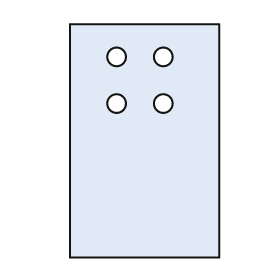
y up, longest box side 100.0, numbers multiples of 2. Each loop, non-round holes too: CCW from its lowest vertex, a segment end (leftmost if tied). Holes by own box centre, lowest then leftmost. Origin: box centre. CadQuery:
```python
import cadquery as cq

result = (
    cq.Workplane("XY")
    .moveTo(-32.0, -50.0)
    .lineTo(32.0, -50.0)
    .lineTo(32.0, 50.0)
    .lineTo(-32.0, 50.0)
    .close()
    .moveTo(-12.0, 16.0)
    .circle(4.0)
    .moveTo(8.0, 16.0)
    .circle(4.0)
    .moveTo(-12.0, 36.0)
    .circle(4.0)
    .moveTo(8.0, 36.0)
    .circle(4.0)
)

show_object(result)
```